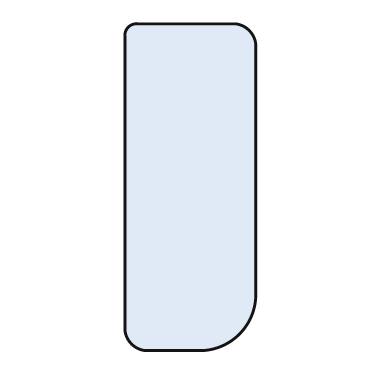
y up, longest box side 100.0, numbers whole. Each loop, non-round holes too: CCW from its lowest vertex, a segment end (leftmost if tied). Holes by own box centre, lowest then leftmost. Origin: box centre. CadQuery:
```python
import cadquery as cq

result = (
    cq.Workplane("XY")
    .moveTo(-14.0, -50.0)
    .lineTo(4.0, -50.0)
    .threePointArc((15.0, -45.0), (20.0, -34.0))
    .lineTo(20.0, 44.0)
    .threePointArc((18.0, 48.0), (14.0, 50.0))
    .lineTo(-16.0, 50.0)
    .threePointArc((-19.0, 49.0), (-20.0, 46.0))
    .lineTo(-20.0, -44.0)
    .threePointArc((-18.0, -48.0), (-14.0, -50.0))
    .close()
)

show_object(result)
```